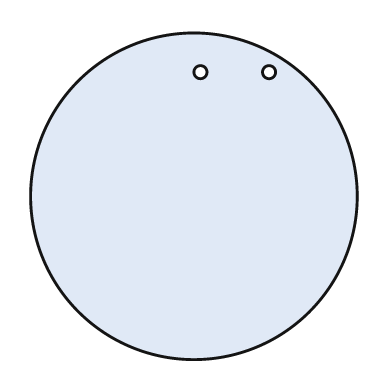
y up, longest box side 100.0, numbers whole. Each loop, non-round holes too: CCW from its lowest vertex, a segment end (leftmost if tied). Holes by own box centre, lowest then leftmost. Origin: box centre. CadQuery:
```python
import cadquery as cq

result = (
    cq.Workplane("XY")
    .moveTo(0.0, 0.0)
    .circle(50.0)
    .moveTo(2.0, 38.0)
    .circle(2.0)
    .moveTo(23.0, 38.0)
    .circle(2.0)
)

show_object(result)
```